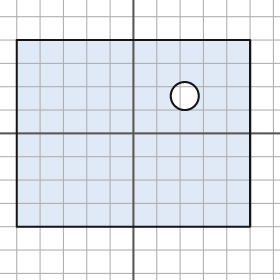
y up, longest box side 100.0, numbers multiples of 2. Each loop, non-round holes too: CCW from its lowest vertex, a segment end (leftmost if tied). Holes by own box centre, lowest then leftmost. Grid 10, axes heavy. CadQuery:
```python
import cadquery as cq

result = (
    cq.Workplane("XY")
    .moveTo(-50.0, -40.0)
    .lineTo(50.0, -40.0)
    .lineTo(50.0, 40.0)
    .lineTo(-50.0, 40.0)
    .close()
    .moveTo(22.0, 16.0)
    .circle(6.0)
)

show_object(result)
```